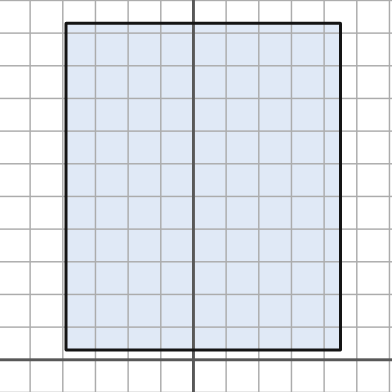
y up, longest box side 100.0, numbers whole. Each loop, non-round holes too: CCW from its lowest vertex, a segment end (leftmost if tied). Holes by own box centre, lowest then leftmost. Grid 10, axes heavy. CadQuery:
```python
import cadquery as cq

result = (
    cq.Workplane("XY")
    .moveTo(-39.0, 3.0)
    .lineTo(45.0, 3.0)
    .lineTo(45.0, 103.0)
    .lineTo(-39.0, 103.0)
    .close()
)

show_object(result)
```